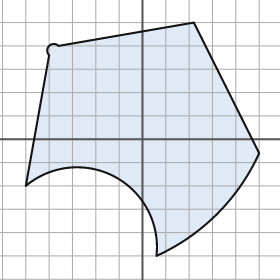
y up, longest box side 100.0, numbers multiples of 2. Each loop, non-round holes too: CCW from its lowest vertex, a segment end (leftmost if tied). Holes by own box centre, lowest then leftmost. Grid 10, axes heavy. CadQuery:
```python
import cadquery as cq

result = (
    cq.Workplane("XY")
    .moveTo(6.0, -50.0)
    .threePointArc((32.0, -32.0), (50.0, -6.0))
    .lineTo(22.0, 50.0)
    .lineTo(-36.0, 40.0)
    .threePointArc((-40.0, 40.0), (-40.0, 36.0))
    .lineTo(-50.0, -20.0)
    .threePointArc((-12.0, -16.0), (6.0, -50.0))
    .close()
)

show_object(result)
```